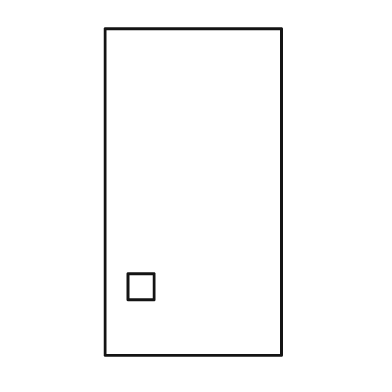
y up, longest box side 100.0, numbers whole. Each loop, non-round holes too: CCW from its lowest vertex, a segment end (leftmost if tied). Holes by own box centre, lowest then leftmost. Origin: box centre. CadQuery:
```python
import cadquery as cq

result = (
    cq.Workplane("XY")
    .moveTo(-27.0, -50.0)
    .lineTo(27.0, -50.0)
    .lineTo(27.0, 50.0)
    .lineTo(-27.0, 50.0)
    .close()
    .moveTo(-20.0, -33.0)
    .lineTo(-12.0, -33.0)
    .lineTo(-12.0, -25.0)
    .lineTo(-20.0, -25.0)
    .close()
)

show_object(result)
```